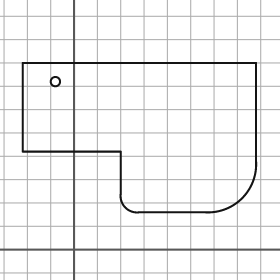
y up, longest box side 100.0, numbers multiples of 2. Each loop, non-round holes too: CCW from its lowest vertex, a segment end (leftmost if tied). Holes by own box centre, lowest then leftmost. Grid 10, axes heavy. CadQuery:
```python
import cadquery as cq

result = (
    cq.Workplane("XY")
    .moveTo(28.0, 16.0)
    .lineTo(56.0, 16.0)
    .threePointArc((72.0, 22.0), (78.0, 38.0))
    .lineTo(78.0, 80.0)
    .lineTo(-22.0, 80.0)
    .lineTo(-22.0, 42.0)
    .lineTo(20.0, 42.0)
    .lineTo(20.0, 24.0)
    .threePointArc((22.0, 18.0), (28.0, 16.0))
    .close()
    .moveTo(-8.0, 72.0)
    .circle(2.0)
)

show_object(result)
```